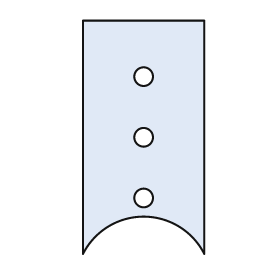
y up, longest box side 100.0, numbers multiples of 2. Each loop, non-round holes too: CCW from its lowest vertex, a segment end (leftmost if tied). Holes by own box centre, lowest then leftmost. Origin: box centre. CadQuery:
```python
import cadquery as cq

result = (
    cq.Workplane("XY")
    .moveTo(-26.0, -50.0)
    .threePointArc((0.0, -34.0), (26.0, -50.0))
    .lineTo(26.0, 50.0)
    .lineTo(-26.0, 50.0)
    .close()
    .moveTo(0.0, -26.0)
    .circle(4.0)
    .moveTo(0.0, 0.0)
    .circle(4.0)
    .moveTo(0.0, 26.0)
    .circle(4.0)
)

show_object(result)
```